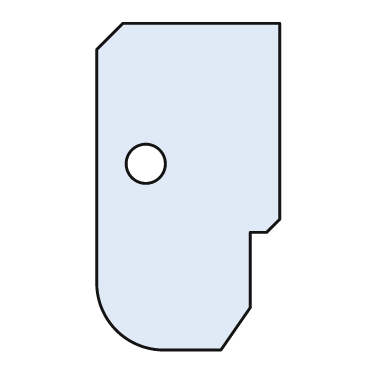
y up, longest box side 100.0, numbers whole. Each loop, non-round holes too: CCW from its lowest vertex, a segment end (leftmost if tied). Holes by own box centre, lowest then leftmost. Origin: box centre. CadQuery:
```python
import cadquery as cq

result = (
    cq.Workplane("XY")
    .moveTo(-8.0, -50.0)
    .lineTo(10.0, -50.0)
    .lineTo(19.0, -37.0)
    .lineTo(19.0, -14.0)
    .lineTo(24.0, -14.0)
    .lineTo(28.0, -10.0)
    .lineTo(28.0, 50.0)
    .lineTo(-20.0, 50.0)
    .lineTo(-28.0, 42.0)
    .lineTo(-28.0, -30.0)
    .threePointArc((-22.0, -44.0), (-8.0, -50.0))
    .close()
    .moveTo(-13.0, 7.0)
    .circle(6.0)
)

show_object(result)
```